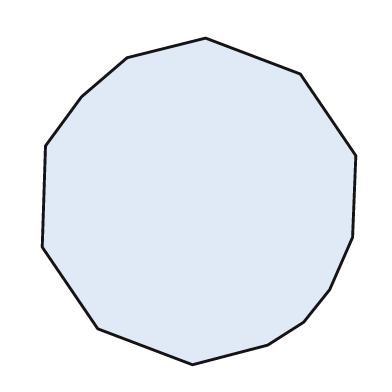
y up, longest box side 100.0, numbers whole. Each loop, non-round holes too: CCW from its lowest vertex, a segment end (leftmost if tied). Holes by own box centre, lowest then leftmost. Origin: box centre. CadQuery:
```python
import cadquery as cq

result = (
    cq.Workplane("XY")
    .moveTo(-2.0, -50.0)
    .lineTo(21.0, -44.0)
    .lineTo(32.0, -37.0)
    .lineTo(40.0, -27.0)
    .lineTo(47.0, -11.0)
    .lineTo(48.0, 14.0)
    .lineTo(31.0, 39.0)
    .lineTo(2.0, 50.0)
    .lineTo(-22.0, 44.0)
    .lineTo(-36.0, 32.0)
    .lineTo(-47.0, 17.0)
    .lineTo(-48.0, -14.0)
    .lineTo(-31.0, -39.0)
    .close()
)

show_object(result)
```